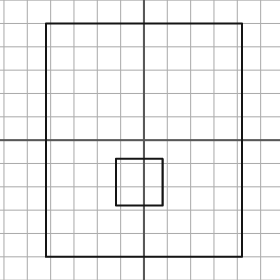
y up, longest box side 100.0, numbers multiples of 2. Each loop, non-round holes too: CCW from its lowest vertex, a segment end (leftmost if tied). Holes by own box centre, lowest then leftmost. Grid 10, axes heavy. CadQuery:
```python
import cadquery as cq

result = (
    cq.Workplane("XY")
    .moveTo(-42.0, -50.0)
    .lineTo(42.0, -50.0)
    .lineTo(42.0, 50.0)
    .lineTo(-42.0, 50.0)
    .close()
    .moveTo(-12.0, -28.0)
    .lineTo(8.0, -28.0)
    .lineTo(8.0, -8.0)
    .lineTo(-12.0, -8.0)
    .close()
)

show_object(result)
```